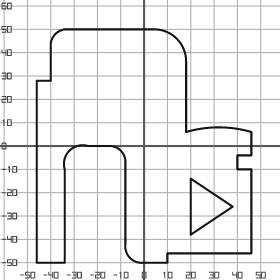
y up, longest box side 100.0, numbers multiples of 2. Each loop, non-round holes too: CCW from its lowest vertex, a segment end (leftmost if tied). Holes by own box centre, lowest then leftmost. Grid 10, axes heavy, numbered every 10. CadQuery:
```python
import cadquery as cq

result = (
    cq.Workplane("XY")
    .moveTo(-46.0, -50.0)
    .lineTo(-34.0, -50.0)
    .lineTo(-34.0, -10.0)
    .threePointArc((-32.0, -2.0), (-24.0, 0.0))
    .lineTo(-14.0, 0.0)
    .threePointArc((-10.0, -2.0), (-8.0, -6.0))
    .lineTo(-8.0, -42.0)
    .threePointArc((-6.0, -48.0), (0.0, -50.0))
    .lineTo(10.0, -50.0)
    .lineTo(10.0, -46.0)
    .lineTo(46.0, -46.0)
    .lineTo(46.0, -10.0)
    .lineTo(40.0, -10.0)
    .lineTo(40.0, -4.0)
    .lineTo(46.0, -4.0)
    .lineTo(46.0, 6.0)
    .threePointArc((32.0, 8.0), (18.0, 6.0))
    .lineTo(18.0, 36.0)
    .threePointArc((14.0, 46.0), (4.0, 50.0))
    .lineTo(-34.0, 50.0)
    .threePointArc((-38.0, 48.0), (-40.0, 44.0))
    .lineTo(-40.0, 28.0)
    .lineTo(-46.0, 28.0)
    .close()
    .moveTo(20.0, -38.0)
    .lineTo(38.0, -26.0)
    .lineTo(20.0, -14.0)
    .close()
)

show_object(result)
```